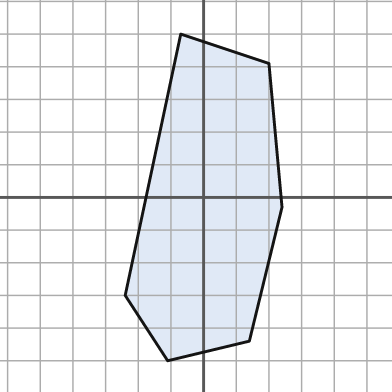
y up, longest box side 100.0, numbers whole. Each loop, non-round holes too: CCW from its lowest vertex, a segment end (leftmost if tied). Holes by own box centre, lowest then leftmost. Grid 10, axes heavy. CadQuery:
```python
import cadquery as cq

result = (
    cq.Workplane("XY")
    .moveTo(-11.0, -50.0)
    .lineTo(14.0, -44.0)
    .lineTo(24.0, -3.0)
    .lineTo(20.0, 41.0)
    .lineTo(-7.0, 50.0)
    .lineTo(-24.0, -30.0)
    .close()
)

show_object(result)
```